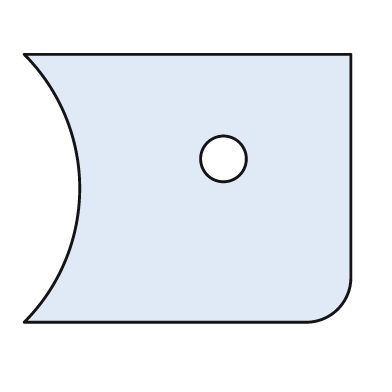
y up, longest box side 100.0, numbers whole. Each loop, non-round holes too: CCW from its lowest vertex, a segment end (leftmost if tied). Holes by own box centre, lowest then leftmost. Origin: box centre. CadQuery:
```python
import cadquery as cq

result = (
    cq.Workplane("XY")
    .moveTo(-50.0, -41.0)
    .lineTo(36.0, -41.0)
    .threePointArc((46.0, -37.0), (50.0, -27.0))
    .lineTo(50.0, 41.0)
    .lineTo(-50.0, 41.0)
    .threePointArc((-33.0, 0.0), (-50.0, -41.0))
    .close()
    .moveTo(11.0, 9.0)
    .circle(7.0)
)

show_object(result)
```